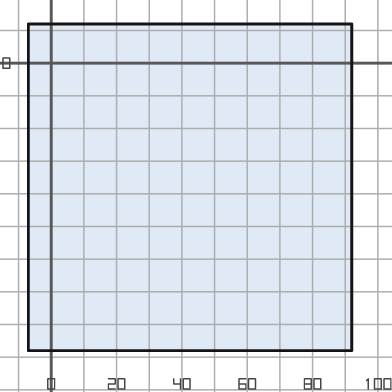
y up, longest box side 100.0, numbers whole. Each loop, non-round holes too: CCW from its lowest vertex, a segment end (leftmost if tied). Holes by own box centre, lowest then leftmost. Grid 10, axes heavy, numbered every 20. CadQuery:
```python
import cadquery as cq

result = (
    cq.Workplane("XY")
    .moveTo(-7.0, -88.0)
    .lineTo(92.0, -88.0)
    .lineTo(92.0, 12.0)
    .lineTo(-7.0, 12.0)
    .close()
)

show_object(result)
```